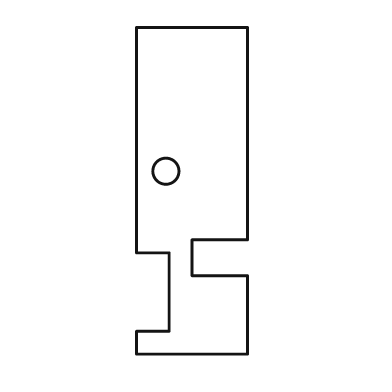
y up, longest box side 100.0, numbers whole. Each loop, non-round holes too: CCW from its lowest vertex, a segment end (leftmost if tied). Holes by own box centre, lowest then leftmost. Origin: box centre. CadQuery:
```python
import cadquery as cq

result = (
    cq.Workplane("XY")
    .moveTo(-17.0, -50.0)
    .lineTo(17.0, -50.0)
    .lineTo(17.0, -26.0)
    .lineTo(0.0, -26.0)
    .lineTo(0.0, -15.0)
    .lineTo(17.0, -15.0)
    .lineTo(17.0, 50.0)
    .lineTo(-17.0, 50.0)
    .lineTo(-17.0, -19.0)
    .lineTo(-7.0, -19.0)
    .lineTo(-7.0, -43.0)
    .lineTo(-17.0, -43.0)
    .close()
    .moveTo(-8.0, 6.0)
    .circle(4.0)
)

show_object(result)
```